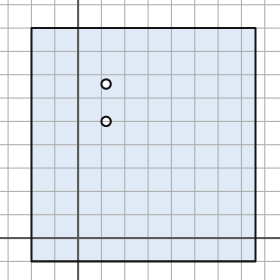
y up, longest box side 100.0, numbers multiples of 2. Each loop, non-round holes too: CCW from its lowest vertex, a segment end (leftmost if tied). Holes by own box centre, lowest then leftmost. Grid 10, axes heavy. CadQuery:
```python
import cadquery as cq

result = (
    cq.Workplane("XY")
    .moveTo(-20.0, -10.0)
    .lineTo(76.0, -10.0)
    .lineTo(76.0, 90.0)
    .lineTo(-20.0, 90.0)
    .close()
    .moveTo(12.0, 50.0)
    .circle(2.0)
    .moveTo(12.0, 66.0)
    .circle(2.0)
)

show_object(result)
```